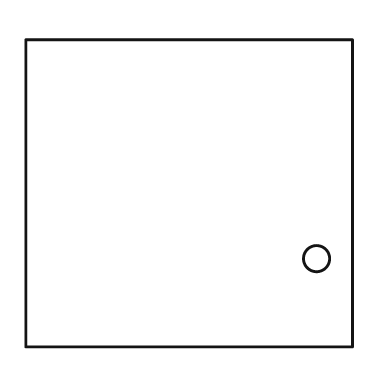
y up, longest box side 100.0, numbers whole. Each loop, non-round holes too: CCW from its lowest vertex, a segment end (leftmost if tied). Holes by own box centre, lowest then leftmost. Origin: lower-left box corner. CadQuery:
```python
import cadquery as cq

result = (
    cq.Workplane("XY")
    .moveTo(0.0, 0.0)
    .lineTo(100.0, 0.0)
    .lineTo(100.0, 94.0)
    .lineTo(0.0, 94.0)
    .close()
    .moveTo(89.0, 27.0)
    .circle(4.0)
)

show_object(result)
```